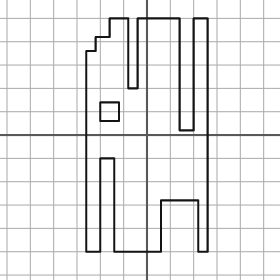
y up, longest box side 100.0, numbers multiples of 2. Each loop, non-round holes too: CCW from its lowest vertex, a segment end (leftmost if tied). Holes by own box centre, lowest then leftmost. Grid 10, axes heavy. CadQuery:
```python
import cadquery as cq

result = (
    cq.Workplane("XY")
    .moveTo(-26.0, -50.0)
    .lineTo(-20.0, -50.0)
    .lineTo(-20.0, -10.0)
    .lineTo(-14.0, -10.0)
    .lineTo(-14.0, -50.0)
    .lineTo(6.0, -50.0)
    .lineTo(6.0, -28.0)
    .lineTo(22.0, -28.0)
    .lineTo(22.0, -50.0)
    .lineTo(26.0, -50.0)
    .lineTo(26.0, 50.0)
    .lineTo(20.0, 50.0)
    .lineTo(20.0, 2.0)
    .lineTo(14.0, 2.0)
    .lineTo(14.0, 50.0)
    .lineTo(-4.0, 50.0)
    .lineTo(-4.0, 20.0)
    .lineTo(-8.0, 20.0)
    .lineTo(-8.0, 50.0)
    .lineTo(-16.0, 50.0)
    .lineTo(-16.0, 42.0)
    .lineTo(-22.0, 42.0)
    .lineTo(-22.0, 36.0)
    .lineTo(-26.0, 36.0)
    .close()
    .moveTo(-20.0, 6.0)
    .lineTo(-12.0, 6.0)
    .lineTo(-12.0, 14.0)
    .lineTo(-20.0, 14.0)
    .close()
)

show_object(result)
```